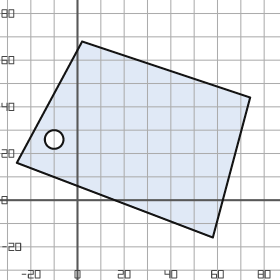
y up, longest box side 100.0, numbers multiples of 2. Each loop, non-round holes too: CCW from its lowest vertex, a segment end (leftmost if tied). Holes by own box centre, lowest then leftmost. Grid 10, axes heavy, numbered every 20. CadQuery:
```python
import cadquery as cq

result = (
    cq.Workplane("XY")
    .moveTo(58.0, -16.0)
    .lineTo(74.0, 44.0)
    .lineTo(2.0, 68.0)
    .lineTo(-26.0, 16.0)
    .close()
    .moveTo(-10.0, 26.0)
    .circle(4.0)
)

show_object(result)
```